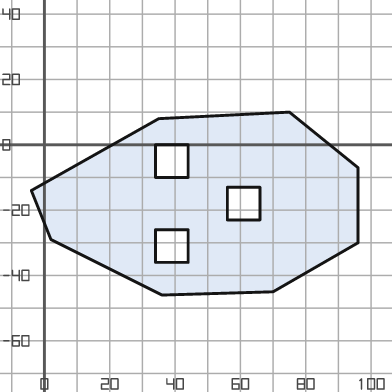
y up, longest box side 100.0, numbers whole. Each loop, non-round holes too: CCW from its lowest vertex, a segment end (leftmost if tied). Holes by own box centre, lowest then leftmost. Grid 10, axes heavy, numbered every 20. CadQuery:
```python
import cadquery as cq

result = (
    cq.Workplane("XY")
    .moveTo(36.0, -46.0)
    .lineTo(70.0, -45.0)
    .lineTo(96.0, -30.0)
    .lineTo(96.0, -7.0)
    .lineTo(75.0, 10.0)
    .lineTo(35.0, 8.0)
    .lineTo(-4.0, -14.0)
    .lineTo(2.0, -29.0)
    .close()
    .moveTo(34.0, -36.0)
    .lineTo(44.0, -36.0)
    .lineTo(44.0, -26.0)
    .lineTo(34.0, -26.0)
    .close()
    .moveTo(56.0, -23.0)
    .lineTo(66.0, -23.0)
    .lineTo(66.0, -13.0)
    .lineTo(56.0, -13.0)
    .close()
    .moveTo(34.0, -10.0)
    .lineTo(44.0, -10.0)
    .lineTo(44.0, 0.0)
    .lineTo(34.0, 0.0)
    .close()
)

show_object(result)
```